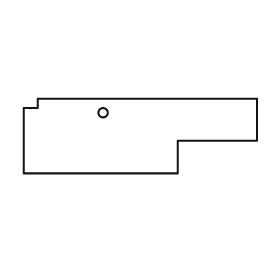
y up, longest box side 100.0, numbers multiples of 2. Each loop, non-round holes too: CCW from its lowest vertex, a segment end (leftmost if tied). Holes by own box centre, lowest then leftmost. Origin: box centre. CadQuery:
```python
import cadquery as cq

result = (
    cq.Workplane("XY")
    .moveTo(-50.0, -16.0)
    .lineTo(16.0, -16.0)
    .lineTo(16.0, -2.0)
    .lineTo(50.0, -2.0)
    .lineTo(50.0, 16.0)
    .lineTo(-44.0, 16.0)
    .lineTo(-44.0, 12.0)
    .lineTo(-50.0, 12.0)
    .close()
    .moveTo(-16.0, 10.0)
    .circle(2.0)
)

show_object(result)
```